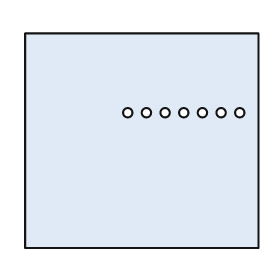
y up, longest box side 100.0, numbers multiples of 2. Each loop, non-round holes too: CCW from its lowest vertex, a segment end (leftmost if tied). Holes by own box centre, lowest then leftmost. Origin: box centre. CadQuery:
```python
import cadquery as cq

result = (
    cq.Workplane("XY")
    .moveTo(-50.0, -46.0)
    .lineTo(50.0, -46.0)
    .lineTo(50.0, 46.0)
    .lineTo(-50.0, 46.0)
    .close()
    .moveTo(-6.0, 12.0)
    .circle(2.0)
    .moveTo(2.0, 12.0)
    .circle(2.0)
    .moveTo(10.0, 12.0)
    .circle(2.0)
    .moveTo(18.0, 12.0)
    .circle(2.0)
    .moveTo(26.0, 12.0)
    .circle(2.0)
    .moveTo(34.0, 12.0)
    .circle(2.0)
    .moveTo(42.0, 12.0)
    .circle(2.0)
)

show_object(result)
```